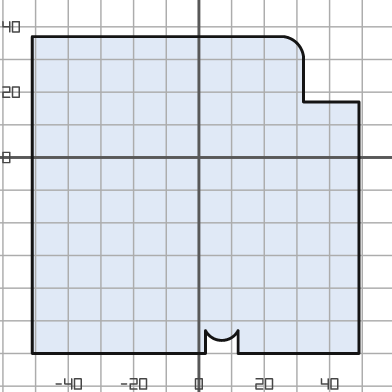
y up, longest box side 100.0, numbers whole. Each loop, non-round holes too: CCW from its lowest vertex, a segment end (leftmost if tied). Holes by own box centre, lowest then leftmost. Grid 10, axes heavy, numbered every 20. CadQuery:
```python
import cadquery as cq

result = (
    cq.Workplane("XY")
    .moveTo(-51.0, -60.0)
    .lineTo(2.0, -60.0)
    .lineTo(2.0, -53.0)
    .threePointArc((7.0, -56.0), (12.0, -53.0))
    .lineTo(12.0, -60.0)
    .lineTo(49.0, -60.0)
    .lineTo(49.0, 17.0)
    .lineTo(32.0, 17.0)
    .lineTo(32.0, 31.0)
    .threePointArc((30.0, 35.0), (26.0, 37.0))
    .lineTo(-51.0, 37.0)
    .close()
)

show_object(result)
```